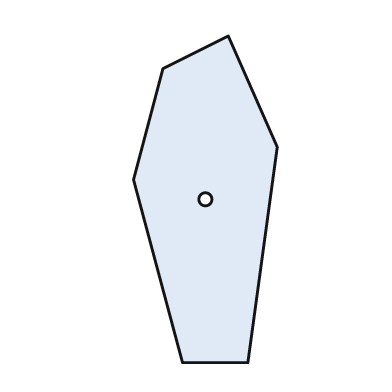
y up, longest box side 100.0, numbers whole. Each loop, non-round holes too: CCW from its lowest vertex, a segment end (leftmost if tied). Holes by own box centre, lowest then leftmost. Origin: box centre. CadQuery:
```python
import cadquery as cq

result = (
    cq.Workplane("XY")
    .moveTo(-7.0, -50.0)
    .lineTo(13.0, -50.0)
    .lineTo(22.0, 16.0)
    .lineTo(7.0, 50.0)
    .lineTo(-13.0, 40.0)
    .lineTo(-22.0, 6.0)
    .close()
    .moveTo(0.0, 0.0)
    .circle(2.0)
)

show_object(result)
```